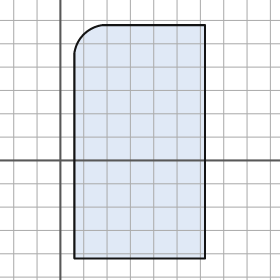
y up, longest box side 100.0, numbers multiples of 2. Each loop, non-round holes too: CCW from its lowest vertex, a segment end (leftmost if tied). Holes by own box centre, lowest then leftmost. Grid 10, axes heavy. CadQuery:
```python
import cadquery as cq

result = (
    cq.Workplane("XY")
    .moveTo(6.0, -42.0)
    .lineTo(62.0, -42.0)
    .lineTo(62.0, 58.0)
    .lineTo(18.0, 58.0)
    .threePointArc((10.0, 54.0), (6.0, 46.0))
    .close()
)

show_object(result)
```